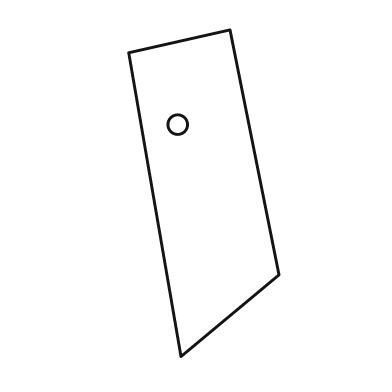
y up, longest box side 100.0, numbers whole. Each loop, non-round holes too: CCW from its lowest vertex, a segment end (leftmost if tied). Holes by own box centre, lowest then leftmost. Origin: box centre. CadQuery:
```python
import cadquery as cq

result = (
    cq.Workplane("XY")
    .moveTo(-7.0, -50.0)
    .lineTo(23.0, -25.0)
    .lineTo(8.0, 50.0)
    .lineTo(-23.0, 43.0)
    .close()
    .moveTo(-8.0, 21.0)
    .circle(3.0)
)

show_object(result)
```